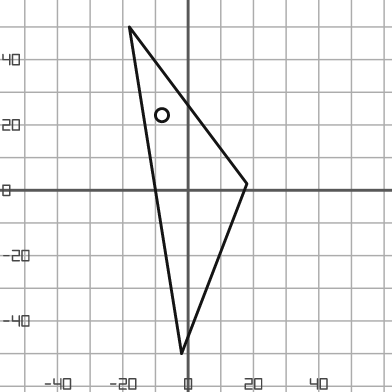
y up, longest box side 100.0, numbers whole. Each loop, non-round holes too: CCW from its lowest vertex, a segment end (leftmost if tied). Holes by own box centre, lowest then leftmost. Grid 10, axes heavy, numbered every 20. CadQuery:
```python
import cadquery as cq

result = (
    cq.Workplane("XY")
    .moveTo(-2.0, -50.0)
    .lineTo(18.0, 2.0)
    .lineTo(-18.0, 50.0)
    .close()
    .moveTo(-8.0, 23.0)
    .circle(2.0)
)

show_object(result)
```